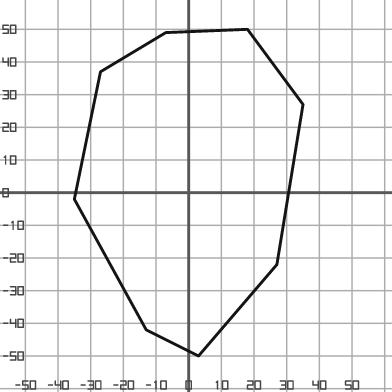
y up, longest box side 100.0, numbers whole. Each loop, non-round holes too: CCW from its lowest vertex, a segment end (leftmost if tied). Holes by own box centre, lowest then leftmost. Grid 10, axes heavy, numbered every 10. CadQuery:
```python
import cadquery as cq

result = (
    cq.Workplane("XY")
    .moveTo(3.0, -50.0)
    .lineTo(27.0, -22.0)
    .lineTo(35.0, 27.0)
    .lineTo(18.0, 50.0)
    .lineTo(-7.0, 49.0)
    .lineTo(-27.0, 37.0)
    .lineTo(-35.0, -2.0)
    .lineTo(-13.0, -42.0)
    .close()
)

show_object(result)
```